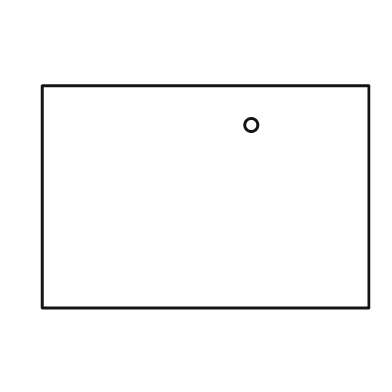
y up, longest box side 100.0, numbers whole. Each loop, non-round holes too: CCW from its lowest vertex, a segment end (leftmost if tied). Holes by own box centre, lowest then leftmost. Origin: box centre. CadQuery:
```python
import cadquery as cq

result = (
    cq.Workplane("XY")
    .moveTo(-50.0, -34.0)
    .lineTo(50.0, -34.0)
    .lineTo(50.0, 34.0)
    .lineTo(-50.0, 34.0)
    .close()
    .moveTo(14.0, 22.0)
    .circle(2.0)
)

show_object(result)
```